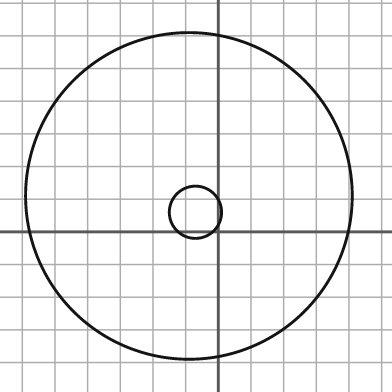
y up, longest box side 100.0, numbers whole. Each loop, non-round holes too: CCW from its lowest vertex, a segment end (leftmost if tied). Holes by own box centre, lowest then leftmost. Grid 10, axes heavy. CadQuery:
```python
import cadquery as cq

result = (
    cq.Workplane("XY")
    .moveTo(-9.0, 11.0)
    .circle(50.0)
    .moveTo(-7.0, 6.0)
    .circle(8.0)
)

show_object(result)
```